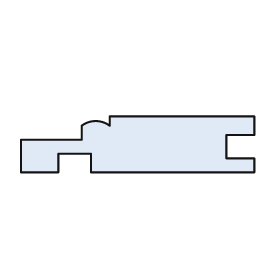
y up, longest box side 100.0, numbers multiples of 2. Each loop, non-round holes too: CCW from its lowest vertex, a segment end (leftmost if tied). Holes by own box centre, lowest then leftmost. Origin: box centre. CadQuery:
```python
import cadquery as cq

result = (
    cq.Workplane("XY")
    .moveTo(-50.0, -12.0)
    .lineTo(-34.0, -12.0)
    .lineTo(-34.0, -4.0)
    .lineTo(-20.0, -4.0)
    .lineTo(-20.0, -12.0)
    .lineTo(50.0, -12.0)
    .lineTo(50.0, -6.0)
    .lineTo(38.0, -6.0)
    .lineTo(38.0, 4.0)
    .lineTo(50.0, 4.0)
    .lineTo(50.0, 12.0)
    .lineTo(-12.0, 12.0)
    .lineTo(-12.0, 8.0)
    .threePointArc((-18.0, 10.0), (-24.0, 8.0))
    .lineTo(-24.0, 2.0)
    .lineTo(-50.0, 2.0)
    .close()
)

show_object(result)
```